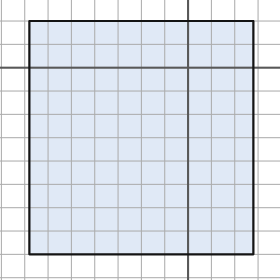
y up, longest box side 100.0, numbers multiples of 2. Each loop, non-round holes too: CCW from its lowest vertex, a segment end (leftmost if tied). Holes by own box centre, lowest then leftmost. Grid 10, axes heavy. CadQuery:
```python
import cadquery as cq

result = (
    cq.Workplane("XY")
    .moveTo(-68.0, -80.0)
    .lineTo(28.0, -80.0)
    .lineTo(28.0, 20.0)
    .lineTo(-68.0, 20.0)
    .close()
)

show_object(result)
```